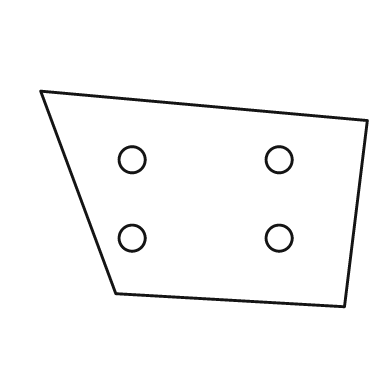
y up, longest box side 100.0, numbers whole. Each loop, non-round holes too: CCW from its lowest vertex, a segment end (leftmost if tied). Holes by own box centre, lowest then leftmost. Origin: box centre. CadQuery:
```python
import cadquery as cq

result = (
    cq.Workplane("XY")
    .moveTo(43.0, -33.0)
    .lineTo(50.0, 24.0)
    .lineTo(-50.0, 33.0)
    .lineTo(-27.0, -29.0)
    .close()
    .moveTo(-22.0, -12.0)
    .circle(4.0)
    .moveTo(23.0, -12.0)
    .circle(4.0)
    .moveTo(-22.0, 12.0)
    .circle(4.0)
    .moveTo(23.0, 12.0)
    .circle(4.0)
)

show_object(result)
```